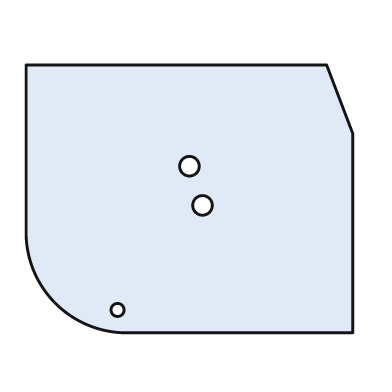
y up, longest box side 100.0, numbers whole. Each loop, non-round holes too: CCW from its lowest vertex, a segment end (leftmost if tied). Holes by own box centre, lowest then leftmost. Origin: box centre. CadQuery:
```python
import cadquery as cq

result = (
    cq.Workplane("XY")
    .moveTo(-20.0, -41.0)
    .lineTo(50.0, -41.0)
    .lineTo(50.0, 20.0)
    .lineTo(42.0, 41.0)
    .lineTo(-50.0, 41.0)
    .lineTo(-50.0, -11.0)
    .threePointArc((-41.0, -32.0), (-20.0, -41.0))
    .close()
    .moveTo(-22.0, -34.0)
    .circle(2.0)
    .moveTo(4.0, -2.0)
    .circle(3.0)
    .moveTo(0.0, 10.0)
    .circle(3.0)
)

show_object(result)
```